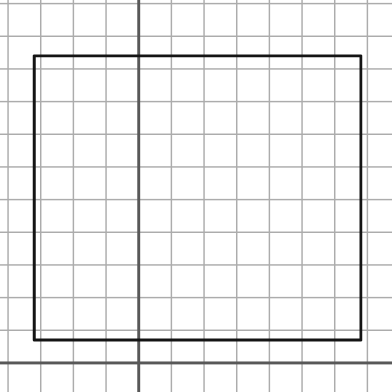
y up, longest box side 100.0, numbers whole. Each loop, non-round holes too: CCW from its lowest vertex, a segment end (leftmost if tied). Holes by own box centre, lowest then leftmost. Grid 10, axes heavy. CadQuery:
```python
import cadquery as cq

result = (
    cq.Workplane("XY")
    .moveTo(-32.0, 7.0)
    .lineTo(68.0, 7.0)
    .lineTo(68.0, 94.0)
    .lineTo(-32.0, 94.0)
    .close()
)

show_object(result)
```